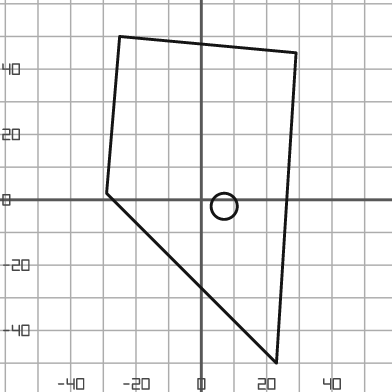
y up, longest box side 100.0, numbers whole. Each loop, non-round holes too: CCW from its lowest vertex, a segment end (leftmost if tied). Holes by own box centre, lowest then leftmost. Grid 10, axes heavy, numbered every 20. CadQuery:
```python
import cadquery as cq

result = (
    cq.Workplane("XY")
    .moveTo(23.0, -50.0)
    .lineTo(29.0, 45.0)
    .lineTo(-25.0, 50.0)
    .lineTo(-29.0, 2.0)
    .close()
    .moveTo(7.0, -2.0)
    .circle(4.0)
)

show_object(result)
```